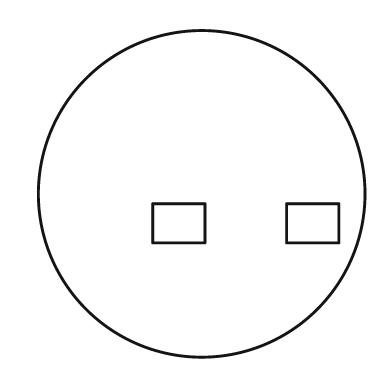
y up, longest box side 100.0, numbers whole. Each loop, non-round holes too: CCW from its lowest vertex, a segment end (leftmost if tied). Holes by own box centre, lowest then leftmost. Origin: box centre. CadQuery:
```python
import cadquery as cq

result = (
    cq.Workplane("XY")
    .moveTo(0.0, 0.0)
    .circle(50.0)
    .moveTo(-15.0, -15.0)
    .lineTo(1.0, -15.0)
    .lineTo(1.0, -3.0)
    .lineTo(-15.0, -3.0)
    .close()
    .moveTo(26.0, -15.0)
    .lineTo(42.0, -15.0)
    .lineTo(42.0, -3.0)
    .lineTo(26.0, -3.0)
    .close()
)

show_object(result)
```